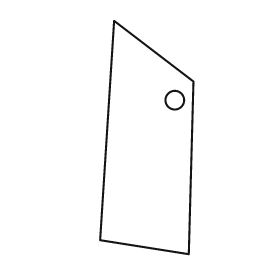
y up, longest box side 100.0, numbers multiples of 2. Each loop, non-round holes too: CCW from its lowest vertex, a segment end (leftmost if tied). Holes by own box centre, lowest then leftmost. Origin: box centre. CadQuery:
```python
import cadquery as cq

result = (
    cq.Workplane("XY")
    .moveTo(18.0, -50.0)
    .lineTo(20.0, 24.0)
    .lineTo(-14.0, 50.0)
    .lineTo(-20.0, -44.0)
    .close()
    .moveTo(12.0, 16.0)
    .circle(4.0)
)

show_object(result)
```